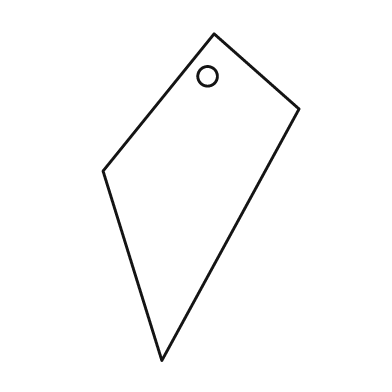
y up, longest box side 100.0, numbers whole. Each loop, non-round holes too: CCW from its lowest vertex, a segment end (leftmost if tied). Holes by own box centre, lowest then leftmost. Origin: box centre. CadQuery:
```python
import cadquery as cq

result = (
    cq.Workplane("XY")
    .moveTo(-12.0, -50.0)
    .lineTo(30.0, 27.0)
    .lineTo(4.0, 50.0)
    .lineTo(-30.0, 8.0)
    .close()
    .moveTo(2.0, 37.0)
    .circle(3.0)
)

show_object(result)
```